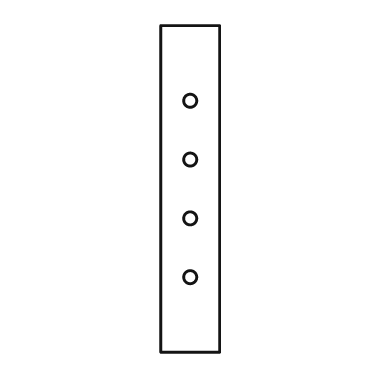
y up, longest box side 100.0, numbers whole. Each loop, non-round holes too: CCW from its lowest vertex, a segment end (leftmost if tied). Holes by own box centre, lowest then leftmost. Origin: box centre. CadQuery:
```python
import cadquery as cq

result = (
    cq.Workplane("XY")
    .moveTo(-9.0, -50.0)
    .lineTo(9.0, -50.0)
    .lineTo(9.0, 50.0)
    .lineTo(-9.0, 50.0)
    .close()
    .moveTo(0.0, -27.0)
    .circle(2.0)
    .moveTo(0.0, -9.0)
    .circle(2.0)
    .moveTo(0.0, 9.0)
    .circle(2.0)
    .moveTo(0.0, 27.0)
    .circle(2.0)
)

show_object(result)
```